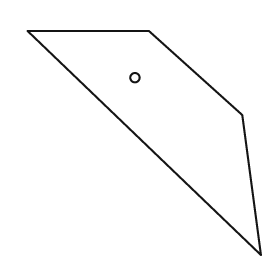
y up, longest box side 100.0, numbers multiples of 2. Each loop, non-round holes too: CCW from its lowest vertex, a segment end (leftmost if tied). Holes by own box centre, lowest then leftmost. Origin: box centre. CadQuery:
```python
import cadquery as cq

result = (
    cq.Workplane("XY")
    .moveTo(50.0, -48.0)
    .lineTo(42.0, 12.0)
    .lineTo(2.0, 48.0)
    .lineTo(-50.0, 48.0)
    .close()
    .moveTo(-4.0, 28.0)
    .circle(2.0)
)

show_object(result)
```